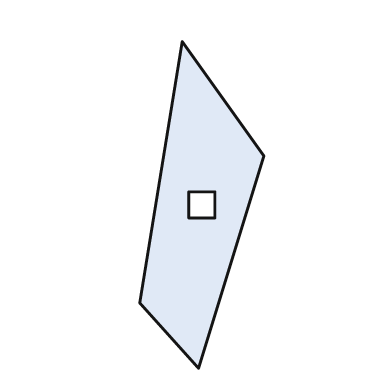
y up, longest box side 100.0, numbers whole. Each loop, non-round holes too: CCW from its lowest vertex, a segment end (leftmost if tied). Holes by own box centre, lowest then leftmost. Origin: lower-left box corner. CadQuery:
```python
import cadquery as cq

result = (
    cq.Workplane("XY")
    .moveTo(18.0, 0.0)
    .lineTo(38.0, 65.0)
    .lineTo(13.0, 100.0)
    .lineTo(0.0, 20.0)
    .close()
    .moveTo(15.0, 46.0)
    .lineTo(23.0, 46.0)
    .lineTo(23.0, 54.0)
    .lineTo(15.0, 54.0)
    .close()
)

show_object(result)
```